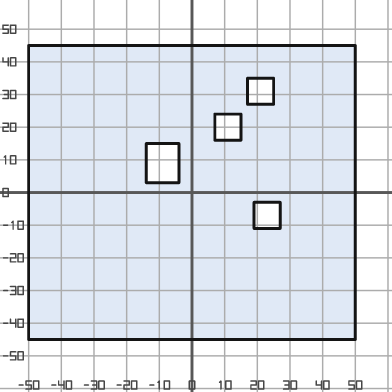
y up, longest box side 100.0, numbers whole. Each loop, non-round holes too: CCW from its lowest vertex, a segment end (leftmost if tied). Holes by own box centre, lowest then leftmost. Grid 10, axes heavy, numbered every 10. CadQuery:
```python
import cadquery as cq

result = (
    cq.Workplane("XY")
    .moveTo(-50.0, -45.0)
    .lineTo(50.0, -45.0)
    .lineTo(50.0, 45.0)
    .lineTo(-50.0, 45.0)
    .close()
    .moveTo(19.0, -11.0)
    .lineTo(27.0, -11.0)
    .lineTo(27.0, -3.0)
    .lineTo(19.0, -3.0)
    .close()
    .moveTo(-14.0, 3.0)
    .lineTo(-4.0, 3.0)
    .lineTo(-4.0, 15.0)
    .lineTo(-14.0, 15.0)
    .close()
    .moveTo(7.0, 16.0)
    .lineTo(15.0, 16.0)
    .lineTo(15.0, 24.0)
    .lineTo(7.0, 24.0)
    .close()
    .moveTo(17.0, 27.0)
    .lineTo(25.0, 27.0)
    .lineTo(25.0, 35.0)
    .lineTo(17.0, 35.0)
    .close()
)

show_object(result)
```